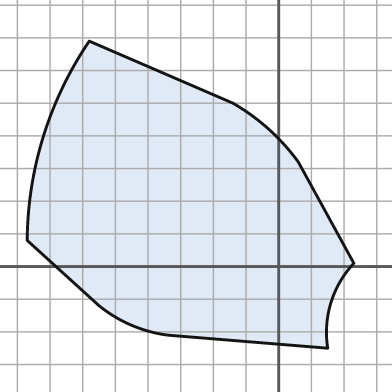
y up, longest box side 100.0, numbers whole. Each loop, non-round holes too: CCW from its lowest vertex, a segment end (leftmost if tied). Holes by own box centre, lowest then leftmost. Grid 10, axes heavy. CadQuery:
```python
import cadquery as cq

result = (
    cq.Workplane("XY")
    .moveTo(15.0, -25.0)
    .threePointArc((16.0, -11.0), (23.0, 1.0))
    .lineTo(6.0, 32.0)
    .threePointArc((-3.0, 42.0), (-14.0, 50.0))
    .lineTo(-58.0, 69.0)
    .threePointArc((-72.0, 40.0), (-77.0, 8.0))
    .lineTo(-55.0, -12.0)
    .threePointArc((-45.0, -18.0), (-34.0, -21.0))
    .close()
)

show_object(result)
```